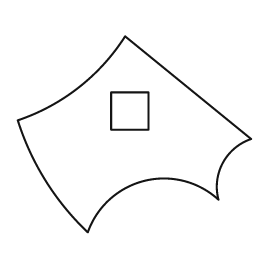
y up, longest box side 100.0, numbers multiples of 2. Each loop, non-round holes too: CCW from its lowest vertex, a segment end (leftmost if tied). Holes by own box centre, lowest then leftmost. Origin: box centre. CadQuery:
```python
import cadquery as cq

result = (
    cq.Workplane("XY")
    .moveTo(-20.0, -42.0)
    .threePointArc((4.0, -20.0), (36.0, -28.0))
    .threePointArc((38.0, -12.0), (50.0, -2.0))
    .lineTo(-4.0, 42.0)
    .threePointArc((-24.0, 20.0), (-50.0, 6.0))
    .threePointArc((-38.0, -20.0), (-20.0, -42.0))
    .close()
    .moveTo(-10.0, 2.0)
    .lineTo(6.0, 2.0)
    .lineTo(6.0, 18.0)
    .lineTo(-10.0, 18.0)
    .close()
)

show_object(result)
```